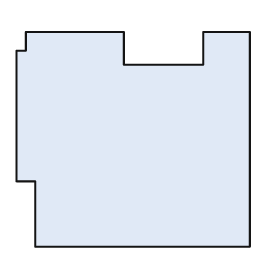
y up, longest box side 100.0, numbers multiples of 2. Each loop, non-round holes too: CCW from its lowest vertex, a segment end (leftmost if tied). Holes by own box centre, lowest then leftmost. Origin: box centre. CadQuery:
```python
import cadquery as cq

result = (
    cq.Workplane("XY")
    .moveTo(-42.0, -46.0)
    .lineTo(50.0, -46.0)
    .lineTo(50.0, 46.0)
    .lineTo(30.0, 46.0)
    .lineTo(30.0, 32.0)
    .lineTo(-4.0, 32.0)
    .lineTo(-4.0, 46.0)
    .lineTo(-46.0, 46.0)
    .lineTo(-46.0, 38.0)
    .lineTo(-50.0, 38.0)
    .lineTo(-50.0, -18.0)
    .lineTo(-42.0, -18.0)
    .close()
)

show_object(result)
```